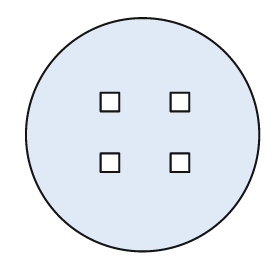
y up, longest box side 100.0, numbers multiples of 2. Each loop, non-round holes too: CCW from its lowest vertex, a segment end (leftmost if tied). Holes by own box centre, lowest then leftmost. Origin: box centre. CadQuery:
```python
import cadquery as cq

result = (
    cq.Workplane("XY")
    .moveTo(0.0, 0.0)
    .circle(50.0)
    .moveTo(-18.0, -16.0)
    .lineTo(-10.0, -16.0)
    .lineTo(-10.0, -8.0)
    .lineTo(-18.0, -8.0)
    .close()
    .moveTo(12.0, -16.0)
    .lineTo(20.0, -16.0)
    .lineTo(20.0, -8.0)
    .lineTo(12.0, -8.0)
    .close()
    .moveTo(-18.0, 10.0)
    .lineTo(-10.0, 10.0)
    .lineTo(-10.0, 18.0)
    .lineTo(-18.0, 18.0)
    .close()
    .moveTo(12.0, 10.0)
    .lineTo(20.0, 10.0)
    .lineTo(20.0, 18.0)
    .lineTo(12.0, 18.0)
    .close()
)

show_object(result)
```